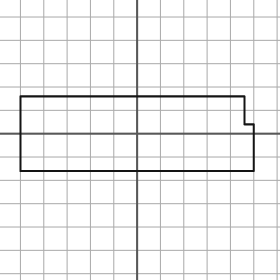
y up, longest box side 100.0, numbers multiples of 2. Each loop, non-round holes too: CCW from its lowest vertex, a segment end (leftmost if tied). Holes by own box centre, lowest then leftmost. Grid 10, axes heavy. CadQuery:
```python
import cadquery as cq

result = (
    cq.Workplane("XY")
    .moveTo(-50.0, -16.0)
    .lineTo(50.0, -16.0)
    .lineTo(50.0, 4.0)
    .lineTo(46.0, 4.0)
    .lineTo(46.0, 16.0)
    .lineTo(-50.0, 16.0)
    .close()
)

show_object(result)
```